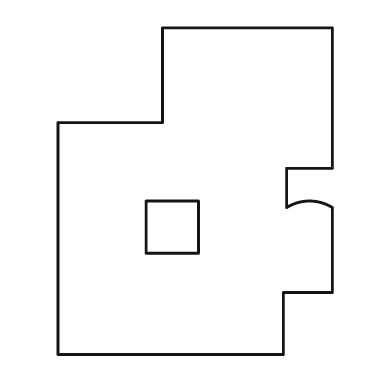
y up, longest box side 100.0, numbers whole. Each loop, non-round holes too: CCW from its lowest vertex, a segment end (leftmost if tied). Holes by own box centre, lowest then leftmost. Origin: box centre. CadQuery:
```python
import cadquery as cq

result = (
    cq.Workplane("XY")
    .moveTo(-42.0, -50.0)
    .lineTo(27.0, -50.0)
    .lineTo(27.0, -31.0)
    .lineTo(42.0, -31.0)
    .lineTo(42.0, -5.0)
    .threePointArc((35.0, -3.0), (28.0, -5.0))
    .lineTo(28.0, 7.0)
    .lineTo(42.0, 7.0)
    .lineTo(42.0, 50.0)
    .lineTo(-10.0, 50.0)
    .lineTo(-10.0, 21.0)
    .lineTo(-42.0, 21.0)
    .close()
    .moveTo(-15.0, -19.0)
    .lineTo(1.0, -19.0)
    .lineTo(1.0, -3.0)
    .lineTo(-15.0, -3.0)
    .close()
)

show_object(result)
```